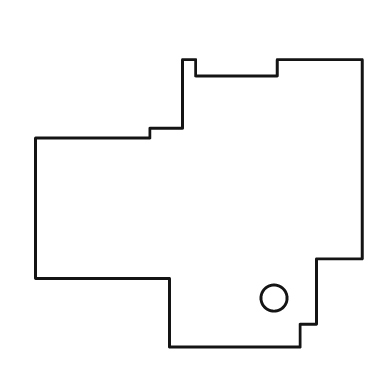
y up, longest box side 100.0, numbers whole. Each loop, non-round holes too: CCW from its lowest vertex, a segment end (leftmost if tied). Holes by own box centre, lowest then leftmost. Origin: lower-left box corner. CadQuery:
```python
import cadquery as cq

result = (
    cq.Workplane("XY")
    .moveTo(41.0, 0.0)
    .lineTo(81.0, 0.0)
    .lineTo(81.0, 7.0)
    .lineTo(86.0, 7.0)
    .lineTo(86.0, 27.0)
    .lineTo(100.0, 27.0)
    .lineTo(100.0, 88.0)
    .lineTo(74.0, 88.0)
    .lineTo(74.0, 83.0)
    .lineTo(49.0, 83.0)
    .lineTo(49.0, 88.0)
    .lineTo(45.0, 88.0)
    .lineTo(45.0, 67.0)
    .lineTo(35.0, 67.0)
    .lineTo(35.0, 64.0)
    .lineTo(0.0, 64.0)
    .lineTo(0.0, 21.0)
    .lineTo(41.0, 21.0)
    .close()
    .moveTo(73.0, 15.0)
    .circle(4.0)
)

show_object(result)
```